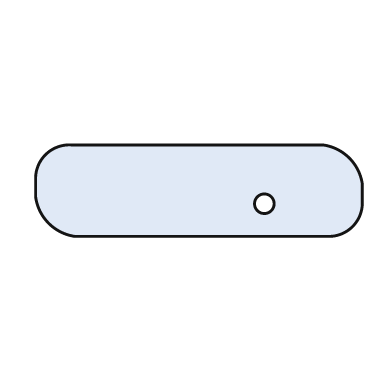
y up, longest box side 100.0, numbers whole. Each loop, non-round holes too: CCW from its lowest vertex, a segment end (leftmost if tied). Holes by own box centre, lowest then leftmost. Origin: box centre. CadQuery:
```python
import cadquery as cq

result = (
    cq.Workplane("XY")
    .moveTo(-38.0, -14.0)
    .lineTo(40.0, -14.0)
    .threePointArc((47.0, -11.0), (50.0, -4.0))
    .lineTo(50.0, 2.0)
    .threePointArc((46.0, 10.0), (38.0, 14.0))
    .lineTo(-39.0, 14.0)
    .threePointArc((-47.0, 11.0), (-50.0, 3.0))
    .lineTo(-50.0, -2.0)
    .threePointArc((-46.0, -10.0), (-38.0, -14.0))
    .close()
    .moveTo(20.0, -4.0)
    .circle(3.0)
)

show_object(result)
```